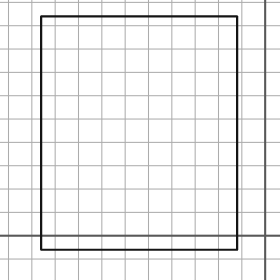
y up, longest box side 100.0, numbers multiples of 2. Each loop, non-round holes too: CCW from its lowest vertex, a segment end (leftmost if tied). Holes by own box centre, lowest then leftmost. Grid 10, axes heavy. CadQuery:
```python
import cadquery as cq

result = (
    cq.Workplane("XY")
    .moveTo(-96.0, -6.0)
    .lineTo(-12.0, -6.0)
    .lineTo(-12.0, 94.0)
    .lineTo(-96.0, 94.0)
    .close()
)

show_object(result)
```